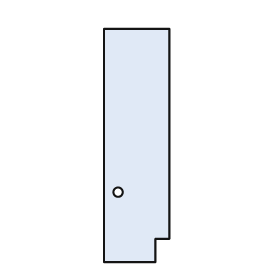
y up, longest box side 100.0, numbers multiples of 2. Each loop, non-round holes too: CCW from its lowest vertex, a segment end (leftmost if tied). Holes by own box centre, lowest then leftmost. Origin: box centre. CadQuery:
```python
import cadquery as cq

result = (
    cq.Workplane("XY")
    .moveTo(-14.0, -50.0)
    .lineTo(8.0, -50.0)
    .lineTo(8.0, -40.0)
    .lineTo(14.0, -40.0)
    .lineTo(14.0, 50.0)
    .lineTo(-14.0, 50.0)
    .close()
    .moveTo(-8.0, -20.0)
    .circle(2.0)
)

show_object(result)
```